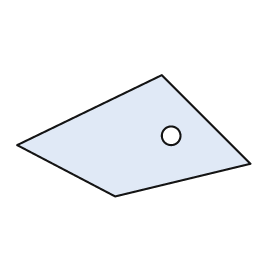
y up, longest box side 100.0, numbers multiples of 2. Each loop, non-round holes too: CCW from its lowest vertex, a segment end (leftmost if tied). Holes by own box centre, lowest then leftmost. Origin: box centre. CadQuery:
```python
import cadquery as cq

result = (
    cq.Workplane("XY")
    .moveTo(-8.0, -26.0)
    .lineTo(50.0, -12.0)
    .lineTo(12.0, 26.0)
    .lineTo(-50.0, -4.0)
    .close()
    .moveTo(16.0, 0.0)
    .circle(4.0)
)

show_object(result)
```